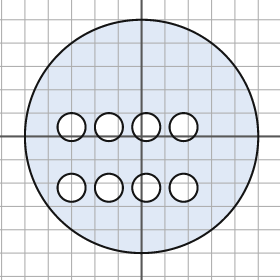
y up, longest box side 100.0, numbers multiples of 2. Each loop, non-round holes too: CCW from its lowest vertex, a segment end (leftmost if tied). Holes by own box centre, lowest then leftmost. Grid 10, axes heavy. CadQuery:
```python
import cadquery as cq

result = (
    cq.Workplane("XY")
    .moveTo(0.0, 0.0)
    .circle(50.0)
    .moveTo(-30.0, -22.0)
    .circle(6.0)
    .moveTo(-14.0, -22.0)
    .circle(6.0)
    .moveTo(2.0, -22.0)
    .circle(6.0)
    .moveTo(18.0, -22.0)
    .circle(6.0)
    .moveTo(-30.0, 4.0)
    .circle(6.0)
    .moveTo(-14.0, 4.0)
    .circle(6.0)
    .moveTo(2.0, 4.0)
    .circle(6.0)
    .moveTo(18.0, 4.0)
    .circle(6.0)
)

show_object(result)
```